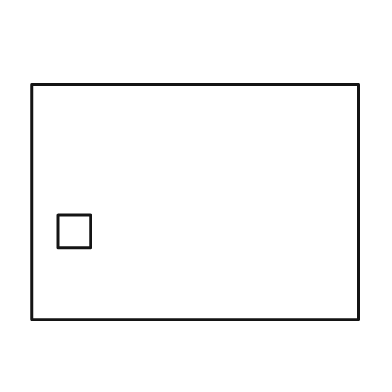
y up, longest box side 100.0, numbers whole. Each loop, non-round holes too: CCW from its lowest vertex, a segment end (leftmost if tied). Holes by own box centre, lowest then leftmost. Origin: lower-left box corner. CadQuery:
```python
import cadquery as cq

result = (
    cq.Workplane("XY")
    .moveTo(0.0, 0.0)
    .lineTo(100.0, 0.0)
    .lineTo(100.0, 72.0)
    .lineTo(0.0, 72.0)
    .close()
    .moveTo(8.0, 22.0)
    .lineTo(18.0, 22.0)
    .lineTo(18.0, 32.0)
    .lineTo(8.0, 32.0)
    .close()
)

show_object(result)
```